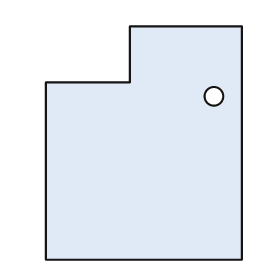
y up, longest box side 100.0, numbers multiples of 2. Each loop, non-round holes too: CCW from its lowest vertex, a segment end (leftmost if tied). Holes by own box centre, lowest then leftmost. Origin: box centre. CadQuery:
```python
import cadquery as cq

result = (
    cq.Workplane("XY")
    .moveTo(-42.0, -50.0)
    .lineTo(42.0, -50.0)
    .lineTo(42.0, 50.0)
    .lineTo(-6.0, 50.0)
    .lineTo(-6.0, 26.0)
    .lineTo(-42.0, 26.0)
    .close()
    .moveTo(30.0, 20.0)
    .circle(4.0)
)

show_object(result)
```